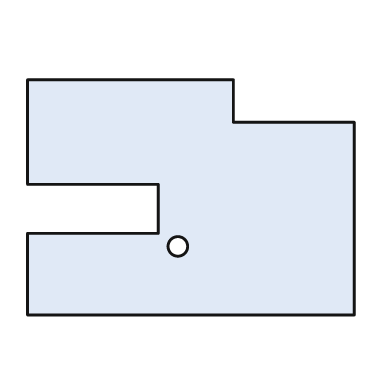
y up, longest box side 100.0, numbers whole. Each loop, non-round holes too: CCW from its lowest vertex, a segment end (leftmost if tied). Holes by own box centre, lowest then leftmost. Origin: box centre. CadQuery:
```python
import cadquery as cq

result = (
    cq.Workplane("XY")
    .moveTo(-50.0, -36.0)
    .lineTo(50.0, -36.0)
    .lineTo(50.0, 23.0)
    .lineTo(13.0, 23.0)
    .lineTo(13.0, 36.0)
    .lineTo(-50.0, 36.0)
    .lineTo(-50.0, 4.0)
    .lineTo(-10.0, 4.0)
    .lineTo(-10.0, -11.0)
    .lineTo(-50.0, -11.0)
    .close()
    .moveTo(-4.0, -15.0)
    .circle(3.0)
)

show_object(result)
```